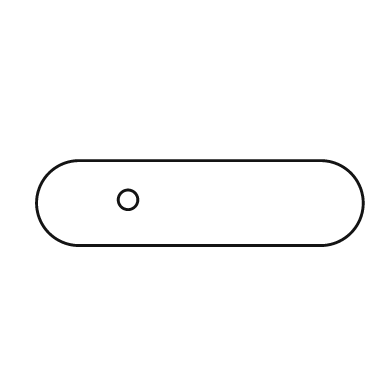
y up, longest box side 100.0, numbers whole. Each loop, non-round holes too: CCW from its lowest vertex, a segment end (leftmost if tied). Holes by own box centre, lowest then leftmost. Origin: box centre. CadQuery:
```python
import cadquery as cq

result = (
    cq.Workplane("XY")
    .moveTo(-37.0, -13.0)
    .lineTo(37.0, -13.0)
    .threePointArc((50.0, 0.0), (37.0, 13.0))
    .lineTo(-37.0, 13.0)
    .threePointArc((-50.0, 0.0), (-37.0, -13.0))
    .close()
    .moveTo(-22.0, 1.0)
    .circle(3.0)
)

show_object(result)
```